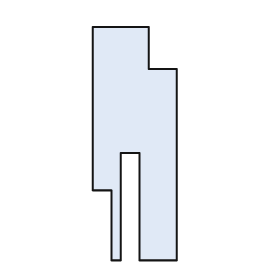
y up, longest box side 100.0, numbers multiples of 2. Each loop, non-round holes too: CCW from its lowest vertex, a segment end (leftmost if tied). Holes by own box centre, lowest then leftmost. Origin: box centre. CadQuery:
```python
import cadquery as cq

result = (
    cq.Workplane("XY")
    .moveTo(-10.0, -50.0)
    .lineTo(-6.0, -50.0)
    .lineTo(-6.0, -4.0)
    .lineTo(2.0, -4.0)
    .lineTo(2.0, -50.0)
    .lineTo(18.0, -50.0)
    .lineTo(18.0, 32.0)
    .lineTo(6.0, 32.0)
    .lineTo(6.0, 50.0)
    .lineTo(-18.0, 50.0)
    .lineTo(-18.0, -20.0)
    .lineTo(-10.0, -20.0)
    .close()
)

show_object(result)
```